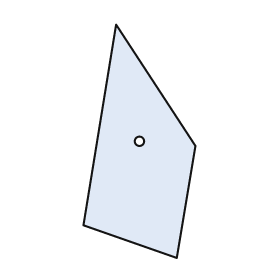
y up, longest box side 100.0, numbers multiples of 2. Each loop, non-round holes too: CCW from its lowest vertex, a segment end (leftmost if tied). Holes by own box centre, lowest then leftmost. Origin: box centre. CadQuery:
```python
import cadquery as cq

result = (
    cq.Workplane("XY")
    .moveTo(16.0, -50.0)
    .lineTo(24.0, -2.0)
    .lineTo(-10.0, 50.0)
    .lineTo(-24.0, -36.0)
    .close()
    .moveTo(0.0, 0.0)
    .circle(2.0)
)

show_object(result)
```